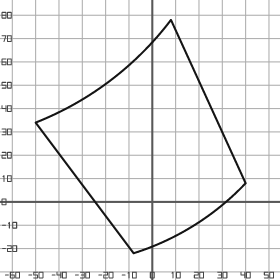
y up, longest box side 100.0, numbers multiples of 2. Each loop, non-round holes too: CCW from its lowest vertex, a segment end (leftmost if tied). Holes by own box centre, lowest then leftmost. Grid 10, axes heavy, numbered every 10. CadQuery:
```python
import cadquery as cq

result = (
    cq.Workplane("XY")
    .moveTo(-8.0, -22.0)
    .threePointArc((18.0, -10.0), (40.0, 8.0))
    .lineTo(8.0, 78.0)
    .threePointArc((-18.0, 52.0), (-50.0, 34.0))
    .close()
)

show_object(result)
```